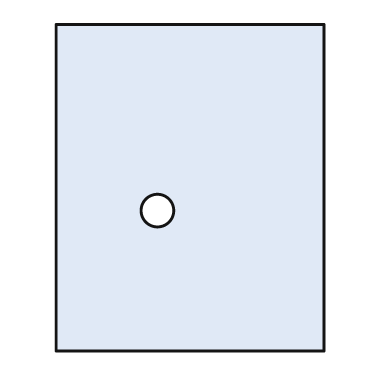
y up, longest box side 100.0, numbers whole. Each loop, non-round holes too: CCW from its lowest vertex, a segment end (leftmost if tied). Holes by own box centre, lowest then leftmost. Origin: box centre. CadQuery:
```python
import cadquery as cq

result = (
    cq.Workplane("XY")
    .moveTo(-41.0, -50.0)
    .lineTo(41.0, -50.0)
    .lineTo(41.0, 50.0)
    .lineTo(-41.0, 50.0)
    .close()
    .moveTo(-10.0, -7.0)
    .circle(5.0)
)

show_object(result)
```